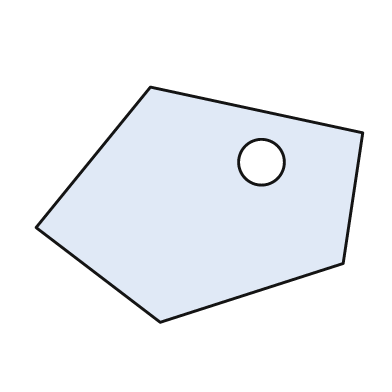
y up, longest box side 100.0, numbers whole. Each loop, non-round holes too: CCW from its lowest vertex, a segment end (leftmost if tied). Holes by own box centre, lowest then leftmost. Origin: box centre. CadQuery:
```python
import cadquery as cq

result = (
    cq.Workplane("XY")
    .moveTo(-12.0, -36.0)
    .lineTo(44.0, -18.0)
    .lineTo(50.0, 22.0)
    .lineTo(-15.0, 36.0)
    .lineTo(-50.0, -7.0)
    .close()
    .moveTo(19.0, 13.0)
    .circle(7.0)
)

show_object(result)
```